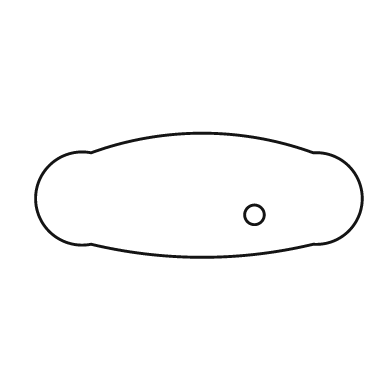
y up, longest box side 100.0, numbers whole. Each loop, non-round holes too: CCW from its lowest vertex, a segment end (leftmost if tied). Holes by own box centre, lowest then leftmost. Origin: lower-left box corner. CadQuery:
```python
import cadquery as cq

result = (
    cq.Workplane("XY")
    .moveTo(17.0, 4.0)
    .threePointArc((51.0, 0.0), (85.0, 4.0))
    .threePointArc((100.0, 18.0), (85.0, 32.0))
    .threePointArc((51.0, 38.0), (17.0, 32.0))
    .threePointArc((0.0, 18.0), (17.0, 4.0))
    .close()
    .moveTo(67.0, 13.0)
    .circle(3.0)
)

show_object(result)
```